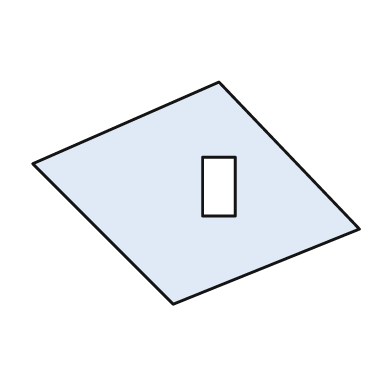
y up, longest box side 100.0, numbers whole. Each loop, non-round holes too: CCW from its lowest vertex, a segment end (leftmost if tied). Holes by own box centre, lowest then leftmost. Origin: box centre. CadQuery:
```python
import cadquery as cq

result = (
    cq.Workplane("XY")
    .moveTo(-7.0, -34.0)
    .lineTo(50.0, -11.0)
    .lineTo(7.0, 34.0)
    .lineTo(-50.0, 9.0)
    .close()
    .moveTo(2.0, -7.0)
    .lineTo(12.0, -7.0)
    .lineTo(12.0, 11.0)
    .lineTo(2.0, 11.0)
    .close()
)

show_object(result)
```